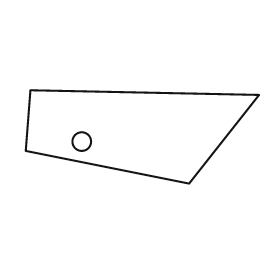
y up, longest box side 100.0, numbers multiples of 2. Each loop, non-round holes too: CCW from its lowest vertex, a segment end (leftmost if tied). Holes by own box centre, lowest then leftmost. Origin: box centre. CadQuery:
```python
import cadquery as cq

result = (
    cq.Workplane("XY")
    .moveTo(20.0, -20.0)
    .lineTo(50.0, 18.0)
    .lineTo(-48.0, 20.0)
    .lineTo(-50.0, -6.0)
    .close()
    .moveTo(-26.0, -2.0)
    .circle(4.0)
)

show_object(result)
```